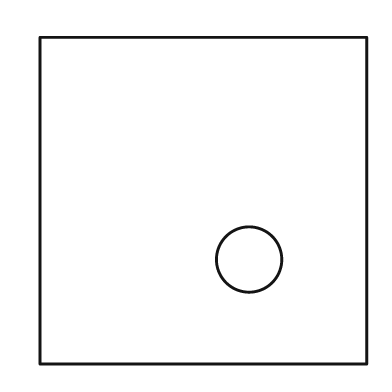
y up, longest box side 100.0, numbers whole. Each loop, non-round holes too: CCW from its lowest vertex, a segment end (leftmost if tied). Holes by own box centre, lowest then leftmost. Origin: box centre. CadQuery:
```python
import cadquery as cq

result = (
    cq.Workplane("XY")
    .moveTo(-50.0, -50.0)
    .lineTo(50.0, -50.0)
    .lineTo(50.0, 50.0)
    .lineTo(-50.0, 50.0)
    .close()
    .moveTo(14.0, -18.0)
    .circle(10.0)
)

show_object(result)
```